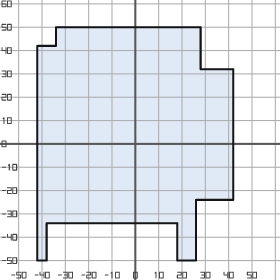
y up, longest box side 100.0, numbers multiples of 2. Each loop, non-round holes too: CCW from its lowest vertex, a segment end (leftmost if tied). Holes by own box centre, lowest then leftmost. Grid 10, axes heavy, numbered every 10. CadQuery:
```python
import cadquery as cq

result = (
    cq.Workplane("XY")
    .moveTo(-42.0, -50.0)
    .lineTo(-38.0, -50.0)
    .lineTo(-38.0, -34.0)
    .lineTo(18.0, -34.0)
    .lineTo(18.0, -50.0)
    .lineTo(26.0, -50.0)
    .lineTo(26.0, -24.0)
    .lineTo(42.0, -24.0)
    .lineTo(42.0, 32.0)
    .lineTo(28.0, 32.0)
    .lineTo(28.0, 50.0)
    .lineTo(-34.0, 50.0)
    .lineTo(-34.0, 42.0)
    .lineTo(-42.0, 42.0)
    .close()
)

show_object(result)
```